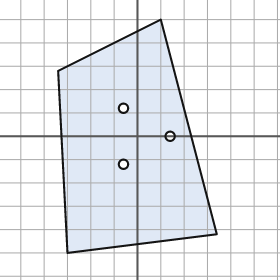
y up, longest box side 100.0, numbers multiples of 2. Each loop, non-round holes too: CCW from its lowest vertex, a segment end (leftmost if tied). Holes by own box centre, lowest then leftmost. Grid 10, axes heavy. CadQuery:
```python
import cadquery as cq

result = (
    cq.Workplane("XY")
    .moveTo(-30.0, -50.0)
    .lineTo(34.0, -42.0)
    .lineTo(10.0, 50.0)
    .lineTo(-34.0, 28.0)
    .close()
    .moveTo(-6.0, -12.0)
    .circle(2.0)
    .moveTo(14.0, 0.0)
    .circle(2.0)
    .moveTo(-6.0, 12.0)
    .circle(2.0)
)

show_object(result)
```